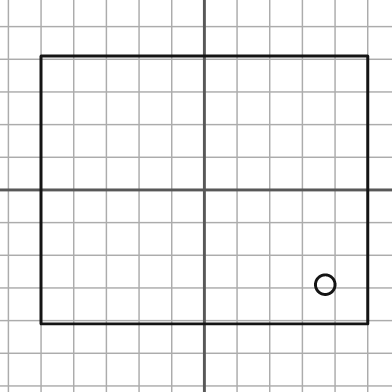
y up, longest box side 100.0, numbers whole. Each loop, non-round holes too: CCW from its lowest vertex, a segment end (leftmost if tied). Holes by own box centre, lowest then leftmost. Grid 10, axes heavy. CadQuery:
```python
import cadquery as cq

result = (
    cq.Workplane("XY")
    .moveTo(-50.0, -41.0)
    .lineTo(50.0, -41.0)
    .lineTo(50.0, 41.0)
    .lineTo(-50.0, 41.0)
    .close()
    .moveTo(37.0, -29.0)
    .circle(3.0)
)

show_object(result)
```